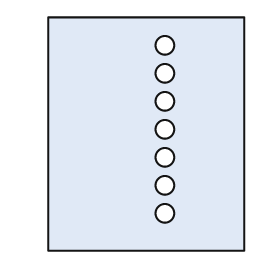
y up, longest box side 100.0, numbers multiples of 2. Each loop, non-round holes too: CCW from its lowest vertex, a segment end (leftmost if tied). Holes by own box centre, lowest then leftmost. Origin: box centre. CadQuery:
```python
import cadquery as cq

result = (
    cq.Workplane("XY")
    .moveTo(-42.0, -50.0)
    .lineTo(42.0, -50.0)
    .lineTo(42.0, 50.0)
    .lineTo(-42.0, 50.0)
    .close()
    .moveTo(8.0, -34.0)
    .circle(4.0)
    .moveTo(8.0, -22.0)
    .circle(4.0)
    .moveTo(8.0, -10.0)
    .circle(4.0)
    .moveTo(8.0, 2.0)
    .circle(4.0)
    .moveTo(8.0, 14.0)
    .circle(4.0)
    .moveTo(8.0, 26.0)
    .circle(4.0)
    .moveTo(8.0, 38.0)
    .circle(4.0)
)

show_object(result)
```